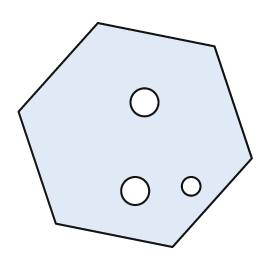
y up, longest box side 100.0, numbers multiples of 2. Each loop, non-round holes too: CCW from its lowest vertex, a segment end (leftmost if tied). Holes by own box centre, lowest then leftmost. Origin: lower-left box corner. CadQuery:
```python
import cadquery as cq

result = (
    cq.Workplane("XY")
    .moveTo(66.0, 0.0)
    .lineTo(100.0, 38.0)
    .lineTo(84.0, 86.0)
    .lineTo(34.0, 96.0)
    .lineTo(0.0, 58.0)
    .lineTo(16.0, 10.0)
    .close()
    .moveTo(50.0, 24.0)
    .circle(6.0)
    .moveTo(74.0, 26.0)
    .circle(4.0)
    .moveTo(54.0, 62.0)
    .circle(6.0)
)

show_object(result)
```